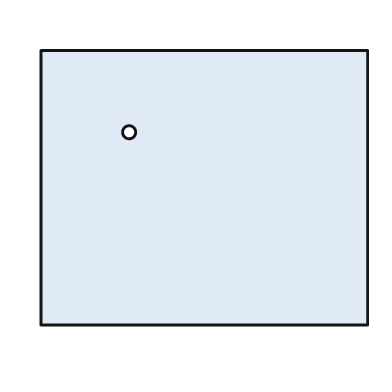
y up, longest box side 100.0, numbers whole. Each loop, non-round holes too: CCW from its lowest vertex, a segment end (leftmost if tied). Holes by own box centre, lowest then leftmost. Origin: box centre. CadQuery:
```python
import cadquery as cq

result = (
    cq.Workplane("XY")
    .moveTo(-50.0, -42.0)
    .lineTo(50.0, -42.0)
    .lineTo(50.0, 42.0)
    .lineTo(-50.0, 42.0)
    .close()
    .moveTo(-23.0, 17.0)
    .circle(2.0)
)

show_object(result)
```